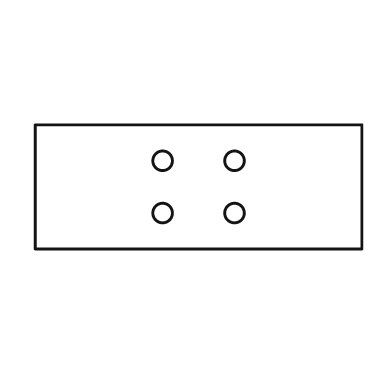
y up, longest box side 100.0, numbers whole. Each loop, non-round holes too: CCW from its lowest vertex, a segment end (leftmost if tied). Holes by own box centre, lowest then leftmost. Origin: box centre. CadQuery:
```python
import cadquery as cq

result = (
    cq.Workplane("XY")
    .moveTo(-50.0, -19.0)
    .lineTo(50.0, -19.0)
    .lineTo(50.0, 19.0)
    .lineTo(-50.0, 19.0)
    .close()
    .moveTo(-11.0, -8.0)
    .circle(3.0)
    .moveTo(11.0, -8.0)
    .circle(3.0)
    .moveTo(-11.0, 8.0)
    .circle(3.0)
    .moveTo(11.0, 8.0)
    .circle(3.0)
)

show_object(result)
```